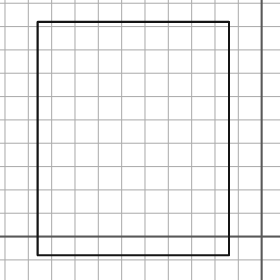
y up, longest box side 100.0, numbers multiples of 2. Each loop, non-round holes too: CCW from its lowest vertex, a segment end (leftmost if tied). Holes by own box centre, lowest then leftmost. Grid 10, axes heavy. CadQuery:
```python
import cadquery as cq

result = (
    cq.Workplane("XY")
    .moveTo(-96.0, -8.0)
    .lineTo(-14.0, -8.0)
    .lineTo(-14.0, 92.0)
    .lineTo(-96.0, 92.0)
    .close()
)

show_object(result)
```